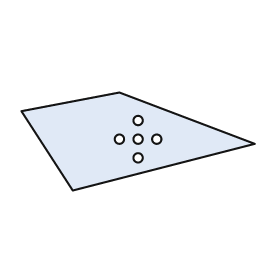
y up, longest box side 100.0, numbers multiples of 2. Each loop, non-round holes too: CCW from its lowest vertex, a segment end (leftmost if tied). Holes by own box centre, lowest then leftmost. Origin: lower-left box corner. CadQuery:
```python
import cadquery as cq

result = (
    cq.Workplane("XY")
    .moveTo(22.0, 0.0)
    .lineTo(100.0, 20.0)
    .lineTo(42.0, 42.0)
    .lineTo(0.0, 34.0)
    .close()
    .moveTo(50.0, 14.0)
    .circle(2.0)
    .moveTo(42.0, 22.0)
    .circle(2.0)
    .moveTo(50.0, 22.0)
    .circle(2.0)
    .moveTo(58.0, 22.0)
    .circle(2.0)
    .moveTo(50.0, 30.0)
    .circle(2.0)
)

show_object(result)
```